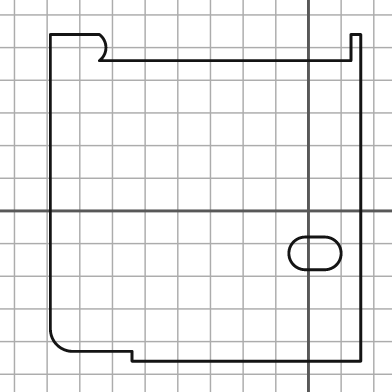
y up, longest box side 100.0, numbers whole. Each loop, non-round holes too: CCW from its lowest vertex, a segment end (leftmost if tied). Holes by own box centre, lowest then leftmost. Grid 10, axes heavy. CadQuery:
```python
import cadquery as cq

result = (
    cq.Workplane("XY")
    .moveTo(-54.0, -46.0)
    .lineTo(16.0, -46.0)
    .lineTo(16.0, 54.0)
    .lineTo(13.0, 54.0)
    .lineTo(13.0, 46.0)
    .lineTo(-64.0, 46.0)
    .threePointArc((-62.0, 50.0), (-64.0, 54.0))
    .lineTo(-79.0, 54.0)
    .lineTo(-79.0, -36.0)
    .threePointArc((-77.0, -41.0), (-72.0, -43.0))
    .lineTo(-54.0, -43.0)
    .close()
    .moveTo(-1.0, -18.0)
    .lineTo(5.0, -18.0)
    .threePointArc((10.0, -13.0), (5.0, -8.0))
    .lineTo(-1.0, -8.0)
    .threePointArc((-6.0, -13.0), (-1.0, -18.0))
    .close()
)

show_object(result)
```